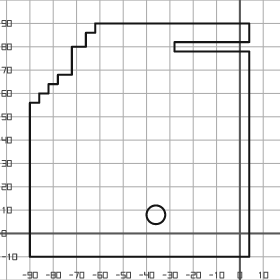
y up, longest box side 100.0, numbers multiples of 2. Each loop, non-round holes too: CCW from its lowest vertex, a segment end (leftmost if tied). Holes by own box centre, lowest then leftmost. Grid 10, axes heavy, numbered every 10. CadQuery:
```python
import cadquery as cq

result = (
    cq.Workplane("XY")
    .moveTo(-90.0, -10.0)
    .lineTo(4.0, -10.0)
    .lineTo(4.0, 78.0)
    .lineTo(-28.0, 78.0)
    .lineTo(-28.0, 82.0)
    .lineTo(4.0, 82.0)
    .lineTo(4.0, 90.0)
    .lineTo(-62.0, 90.0)
    .lineTo(-62.0, 86.0)
    .lineTo(-66.0, 86.0)
    .lineTo(-66.0, 80.0)
    .lineTo(-72.0, 80.0)
    .lineTo(-72.0, 68.0)
    .lineTo(-78.0, 68.0)
    .lineTo(-78.0, 64.0)
    .lineTo(-82.0, 64.0)
    .lineTo(-82.0, 60.0)
    .lineTo(-86.0, 60.0)
    .lineTo(-86.0, 56.0)
    .lineTo(-90.0, 56.0)
    .close()
    .moveTo(-36.0, 8.0)
    .circle(4.0)
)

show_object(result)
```